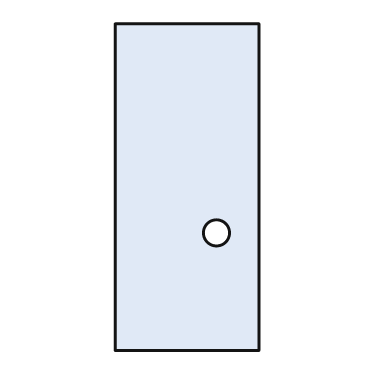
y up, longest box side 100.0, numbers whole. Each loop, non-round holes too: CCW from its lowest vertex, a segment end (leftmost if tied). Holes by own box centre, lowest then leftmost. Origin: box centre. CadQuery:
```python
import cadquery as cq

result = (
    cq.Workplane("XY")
    .moveTo(-22.0, -50.0)
    .lineTo(22.0, -50.0)
    .lineTo(22.0, 50.0)
    .lineTo(-22.0, 50.0)
    .close()
    .moveTo(9.0, -14.0)
    .circle(4.0)
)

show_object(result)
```